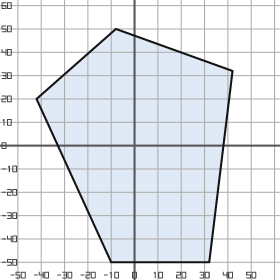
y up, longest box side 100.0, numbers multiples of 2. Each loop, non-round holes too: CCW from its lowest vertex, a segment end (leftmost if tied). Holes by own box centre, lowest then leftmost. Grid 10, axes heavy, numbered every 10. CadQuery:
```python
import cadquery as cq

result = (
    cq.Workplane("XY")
    .moveTo(-10.0, -50.0)
    .lineTo(32.0, -50.0)
    .lineTo(42.0, 32.0)
    .lineTo(-8.0, 50.0)
    .lineTo(-42.0, 20.0)
    .close()
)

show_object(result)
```